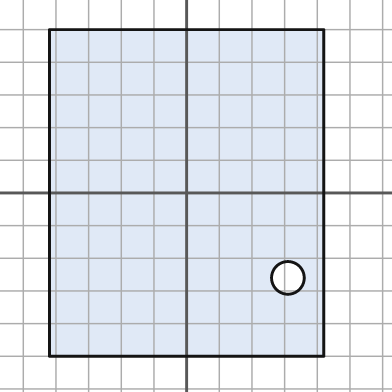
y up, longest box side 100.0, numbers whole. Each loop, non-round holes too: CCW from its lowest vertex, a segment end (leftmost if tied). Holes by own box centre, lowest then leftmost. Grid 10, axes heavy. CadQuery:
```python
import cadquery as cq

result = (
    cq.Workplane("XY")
    .moveTo(-42.0, -50.0)
    .lineTo(42.0, -50.0)
    .lineTo(42.0, 50.0)
    .lineTo(-42.0, 50.0)
    .close()
    .moveTo(31.0, -26.0)
    .circle(5.0)
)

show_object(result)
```